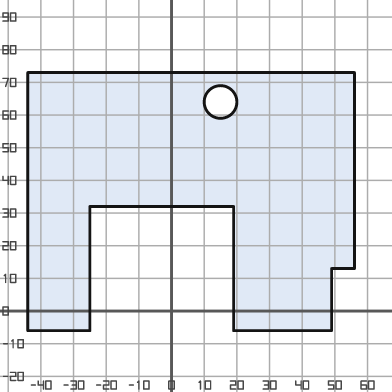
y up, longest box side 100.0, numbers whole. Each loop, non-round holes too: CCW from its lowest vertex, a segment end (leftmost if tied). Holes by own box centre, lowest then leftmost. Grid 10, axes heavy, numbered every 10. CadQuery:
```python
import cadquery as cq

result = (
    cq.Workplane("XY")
    .moveTo(-44.0, -6.0)
    .lineTo(-25.0, -6.0)
    .lineTo(-25.0, 32.0)
    .lineTo(19.0, 32.0)
    .lineTo(19.0, -6.0)
    .lineTo(49.0, -6.0)
    .lineTo(49.0, 13.0)
    .lineTo(56.0, 13.0)
    .lineTo(56.0, 73.0)
    .lineTo(-44.0, 73.0)
    .close()
    .moveTo(15.0, 64.0)
    .circle(5.0)
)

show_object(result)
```